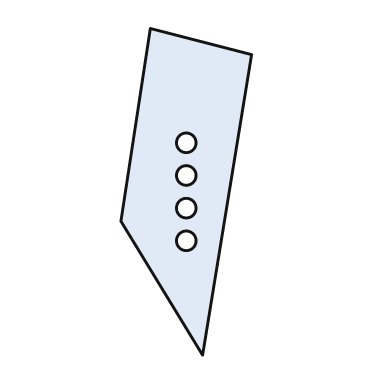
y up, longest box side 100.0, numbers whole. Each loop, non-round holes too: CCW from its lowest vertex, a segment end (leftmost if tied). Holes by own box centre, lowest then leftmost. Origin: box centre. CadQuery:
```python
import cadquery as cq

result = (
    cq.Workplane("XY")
    .moveTo(5.0, -50.0)
    .lineTo(20.0, 42.0)
    .lineTo(-11.0, 50.0)
    .lineTo(-20.0, -9.0)
    .close()
    .moveTo(0.0, -15.0)
    .circle(3.0)
    .moveTo(0.0, -5.0)
    .circle(3.0)
    .moveTo(0.0, 5.0)
    .circle(3.0)
    .moveTo(0.0, 15.0)
    .circle(3.0)
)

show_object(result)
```